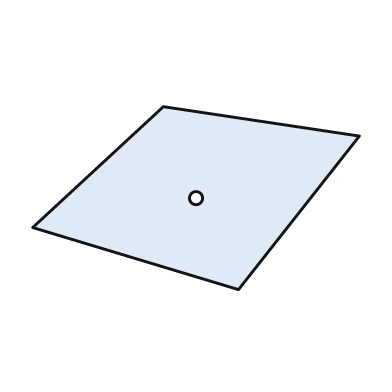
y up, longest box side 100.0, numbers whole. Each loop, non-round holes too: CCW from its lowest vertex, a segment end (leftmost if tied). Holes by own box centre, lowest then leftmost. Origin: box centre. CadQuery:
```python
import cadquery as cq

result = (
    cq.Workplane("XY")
    .moveTo(13.0, -28.0)
    .lineTo(50.0, 19.0)
    .lineTo(-10.0, 28.0)
    .lineTo(-50.0, -9.0)
    .close()
    .moveTo(0.0, 0.0)
    .circle(2.0)
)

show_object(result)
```